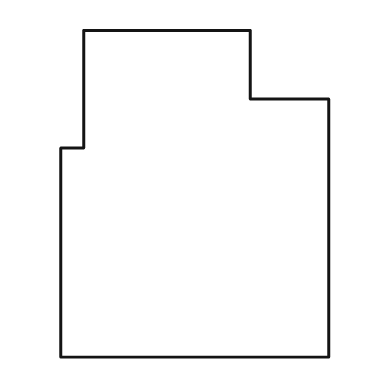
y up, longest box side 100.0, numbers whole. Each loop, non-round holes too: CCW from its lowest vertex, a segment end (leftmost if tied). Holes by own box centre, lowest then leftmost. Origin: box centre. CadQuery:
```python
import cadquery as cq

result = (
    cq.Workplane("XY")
    .moveTo(-41.0, -50.0)
    .lineTo(41.0, -50.0)
    .lineTo(41.0, 29.0)
    .lineTo(17.0, 29.0)
    .lineTo(17.0, 50.0)
    .lineTo(-34.0, 50.0)
    .lineTo(-34.0, 14.0)
    .lineTo(-41.0, 14.0)
    .close()
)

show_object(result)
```